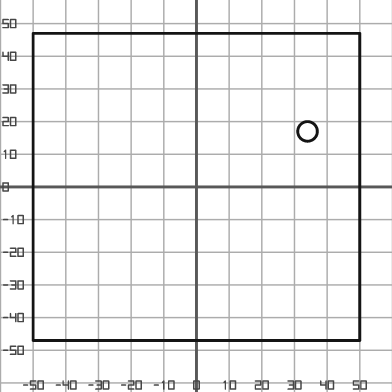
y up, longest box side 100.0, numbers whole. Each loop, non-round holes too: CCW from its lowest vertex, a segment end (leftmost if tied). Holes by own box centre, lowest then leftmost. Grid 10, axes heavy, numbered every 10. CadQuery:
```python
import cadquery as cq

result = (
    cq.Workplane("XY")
    .moveTo(-50.0, -47.0)
    .lineTo(50.0, -47.0)
    .lineTo(50.0, 47.0)
    .lineTo(-50.0, 47.0)
    .close()
    .moveTo(34.0, 17.0)
    .circle(3.0)
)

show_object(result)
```